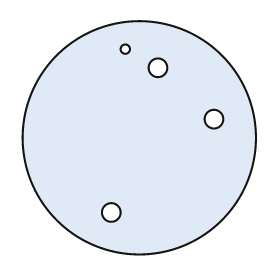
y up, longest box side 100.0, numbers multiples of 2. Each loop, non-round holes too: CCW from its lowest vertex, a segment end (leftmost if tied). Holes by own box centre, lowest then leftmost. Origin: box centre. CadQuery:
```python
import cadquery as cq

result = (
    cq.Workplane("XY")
    .moveTo(0.0, 0.0)
    .circle(50.0)
    .moveTo(-12.0, -32.0)
    .circle(4.0)
    .moveTo(32.0, 8.0)
    .circle(4.0)
    .moveTo(8.0, 30.0)
    .circle(4.0)
    .moveTo(-6.0, 38.0)
    .circle(2.0)
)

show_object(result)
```